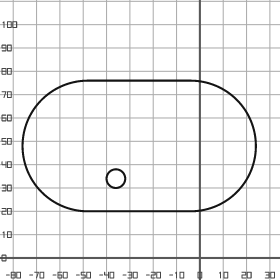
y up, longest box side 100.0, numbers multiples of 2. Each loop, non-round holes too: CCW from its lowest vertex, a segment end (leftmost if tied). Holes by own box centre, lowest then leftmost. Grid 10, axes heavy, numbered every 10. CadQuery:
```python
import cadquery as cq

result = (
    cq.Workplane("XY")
    .moveTo(-48.0, 20.0)
    .lineTo(-4.0, 20.0)
    .threePointArc((24.0, 48.0), (-4.0, 76.0))
    .lineTo(-48.0, 76.0)
    .threePointArc((-76.0, 48.0), (-48.0, 20.0))
    .close()
    .moveTo(-36.0, 34.0)
    .circle(4.0)
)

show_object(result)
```